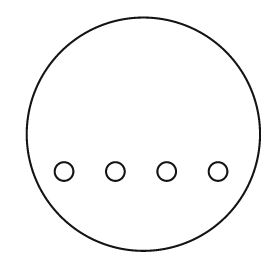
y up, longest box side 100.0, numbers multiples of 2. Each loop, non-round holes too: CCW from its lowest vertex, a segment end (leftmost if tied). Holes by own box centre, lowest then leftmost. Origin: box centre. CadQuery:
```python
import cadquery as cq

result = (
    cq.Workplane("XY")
    .moveTo(0.0, 0.0)
    .circle(50.0)
    .moveTo(-34.0, -16.0)
    .circle(4.0)
    .moveTo(-12.0, -16.0)
    .circle(4.0)
    .moveTo(10.0, -16.0)
    .circle(4.0)
    .moveTo(32.0, -16.0)
    .circle(4.0)
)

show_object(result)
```